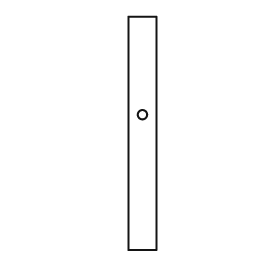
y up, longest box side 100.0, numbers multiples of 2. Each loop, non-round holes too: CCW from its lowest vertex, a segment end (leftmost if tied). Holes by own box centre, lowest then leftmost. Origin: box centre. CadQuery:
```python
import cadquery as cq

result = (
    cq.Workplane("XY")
    .moveTo(-6.0, -50.0)
    .lineTo(6.0, -50.0)
    .lineTo(6.0, 50.0)
    .lineTo(-6.0, 50.0)
    .close()
    .moveTo(0.0, 8.0)
    .circle(2.0)
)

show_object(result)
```